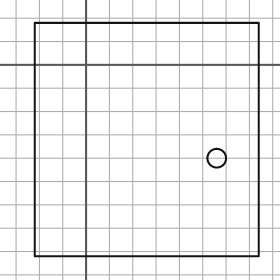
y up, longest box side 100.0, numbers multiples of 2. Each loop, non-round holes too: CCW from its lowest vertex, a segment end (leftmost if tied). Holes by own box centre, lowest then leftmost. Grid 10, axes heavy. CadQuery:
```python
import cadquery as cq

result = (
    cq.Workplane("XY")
    .moveTo(-22.0, -82.0)
    .lineTo(74.0, -82.0)
    .lineTo(74.0, 18.0)
    .lineTo(-22.0, 18.0)
    .close()
    .moveTo(56.0, -40.0)
    .circle(4.0)
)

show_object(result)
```